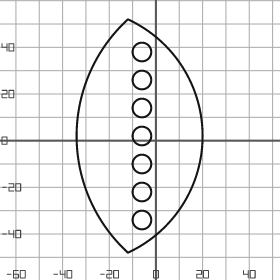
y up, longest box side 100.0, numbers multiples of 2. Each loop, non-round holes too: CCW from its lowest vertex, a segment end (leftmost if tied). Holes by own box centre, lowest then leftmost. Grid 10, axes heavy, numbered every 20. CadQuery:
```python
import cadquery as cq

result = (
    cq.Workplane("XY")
    .moveTo(-12.0, -48.0)
    .threePointArc((20.0, 2.0), (-12.0, 52.0))
    .threePointArc((-34.0, 2.0), (-12.0, -48.0))
    .close()
    .moveTo(-6.0, -34.0)
    .circle(4.0)
    .moveTo(-6.0, -22.0)
    .circle(4.0)
    .moveTo(-6.0, -10.0)
    .circle(4.0)
    .moveTo(-6.0, 2.0)
    .circle(4.0)
    .moveTo(-6.0, 14.0)
    .circle(4.0)
    .moveTo(-6.0, 26.0)
    .circle(4.0)
    .moveTo(-6.0, 38.0)
    .circle(4.0)
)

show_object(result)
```